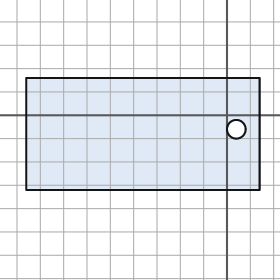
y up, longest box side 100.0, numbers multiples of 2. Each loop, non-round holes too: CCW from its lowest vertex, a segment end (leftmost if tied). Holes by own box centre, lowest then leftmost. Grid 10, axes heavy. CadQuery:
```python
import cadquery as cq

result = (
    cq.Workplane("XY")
    .moveTo(-86.0, -32.0)
    .lineTo(14.0, -32.0)
    .lineTo(14.0, 16.0)
    .lineTo(-86.0, 16.0)
    .close()
    .moveTo(4.0, -6.0)
    .circle(4.0)
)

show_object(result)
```